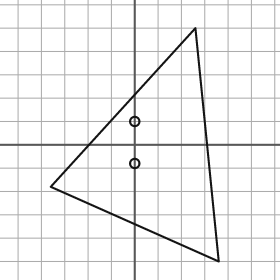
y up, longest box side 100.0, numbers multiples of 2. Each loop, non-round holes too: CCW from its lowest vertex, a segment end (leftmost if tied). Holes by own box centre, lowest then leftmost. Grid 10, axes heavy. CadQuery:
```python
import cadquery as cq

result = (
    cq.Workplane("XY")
    .moveTo(36.0, -50.0)
    .lineTo(26.0, 50.0)
    .lineTo(-36.0, -18.0)
    .close()
    .moveTo(0.0, -8.0)
    .circle(2.0)
    .moveTo(0.0, 10.0)
    .circle(2.0)
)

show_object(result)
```